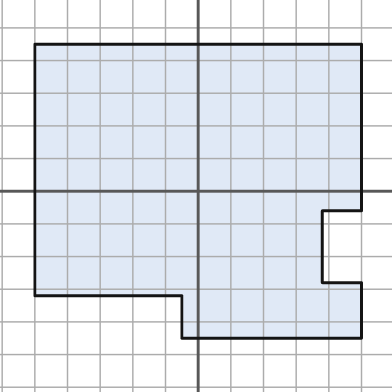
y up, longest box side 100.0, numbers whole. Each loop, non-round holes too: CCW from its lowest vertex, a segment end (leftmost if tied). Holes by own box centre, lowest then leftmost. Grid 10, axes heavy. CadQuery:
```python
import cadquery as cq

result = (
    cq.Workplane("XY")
    .moveTo(-5.0, -45.0)
    .lineTo(50.0, -45.0)
    .lineTo(50.0, -28.0)
    .lineTo(38.0, -28.0)
    .lineTo(38.0, -6.0)
    .lineTo(50.0, -6.0)
    .lineTo(50.0, 45.0)
    .lineTo(-50.0, 45.0)
    .lineTo(-50.0, -32.0)
    .lineTo(-5.0, -32.0)
    .close()
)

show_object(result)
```